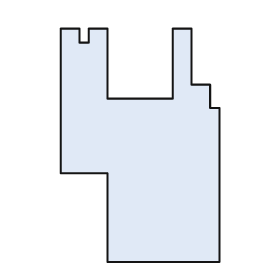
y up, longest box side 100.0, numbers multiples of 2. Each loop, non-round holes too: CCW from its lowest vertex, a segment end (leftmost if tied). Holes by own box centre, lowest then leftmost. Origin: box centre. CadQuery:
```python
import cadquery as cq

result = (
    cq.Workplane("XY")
    .moveTo(-14.0, -50.0)
    .lineTo(34.0, -50.0)
    .lineTo(34.0, 16.0)
    .lineTo(30.0, 16.0)
    .lineTo(30.0, 26.0)
    .lineTo(22.0, 26.0)
    .lineTo(22.0, 50.0)
    .lineTo(14.0, 50.0)
    .lineTo(14.0, 20.0)
    .lineTo(-14.0, 20.0)
    .lineTo(-14.0, 50.0)
    .lineTo(-22.0, 50.0)
    .lineTo(-22.0, 44.0)
    .lineTo(-26.0, 44.0)
    .lineTo(-26.0, 50.0)
    .lineTo(-34.0, 50.0)
    .lineTo(-34.0, -12.0)
    .lineTo(-14.0, -12.0)
    .close()
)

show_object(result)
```